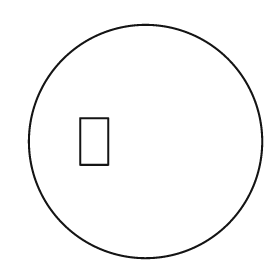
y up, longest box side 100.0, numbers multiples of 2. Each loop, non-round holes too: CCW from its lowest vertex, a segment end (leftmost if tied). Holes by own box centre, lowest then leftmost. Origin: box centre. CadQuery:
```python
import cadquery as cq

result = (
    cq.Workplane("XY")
    .moveTo(0.0, 0.0)
    .circle(50.0)
    .moveTo(-28.0, -10.0)
    .lineTo(-16.0, -10.0)
    .lineTo(-16.0, 10.0)
    .lineTo(-28.0, 10.0)
    .close()
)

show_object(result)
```